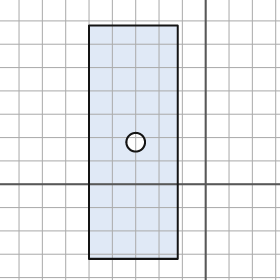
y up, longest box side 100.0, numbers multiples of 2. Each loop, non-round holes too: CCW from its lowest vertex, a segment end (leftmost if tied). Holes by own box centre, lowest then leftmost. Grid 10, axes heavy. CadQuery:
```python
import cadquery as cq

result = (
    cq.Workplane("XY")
    .moveTo(-50.0, -32.0)
    .lineTo(-12.0, -32.0)
    .lineTo(-12.0, 68.0)
    .lineTo(-50.0, 68.0)
    .close()
    .moveTo(-30.0, 18.0)
    .circle(4.0)
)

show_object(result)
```